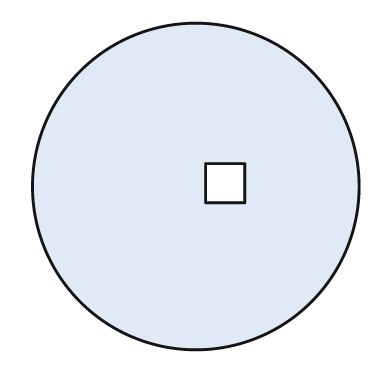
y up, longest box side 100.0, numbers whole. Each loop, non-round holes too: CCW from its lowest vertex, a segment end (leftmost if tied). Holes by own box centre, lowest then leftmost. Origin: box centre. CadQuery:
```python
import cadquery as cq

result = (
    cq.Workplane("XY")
    .moveTo(0.0, 0.0)
    .circle(50.0)
    .moveTo(3.0, -5.0)
    .lineTo(15.0, -5.0)
    .lineTo(15.0, 7.0)
    .lineTo(3.0, 7.0)
    .close()
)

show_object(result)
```